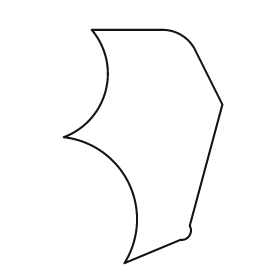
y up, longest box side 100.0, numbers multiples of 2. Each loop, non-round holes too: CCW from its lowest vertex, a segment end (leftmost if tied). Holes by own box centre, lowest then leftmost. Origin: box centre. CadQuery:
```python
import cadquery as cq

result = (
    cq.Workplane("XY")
    .moveTo(-8.0, -50.0)
    .lineTo(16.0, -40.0)
    .threePointArc((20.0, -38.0), (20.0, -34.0))
    .lineTo(34.0, 18.0)
    .lineTo(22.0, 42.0)
    .threePointArc((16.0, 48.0), (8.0, 50.0))
    .lineTo(-22.0, 50.0)
    .threePointArc((-16.0, 24.0), (-34.0, 4.0))
    .threePointArc((-6.0, -16.0), (-8.0, -50.0))
    .close()
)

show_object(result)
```